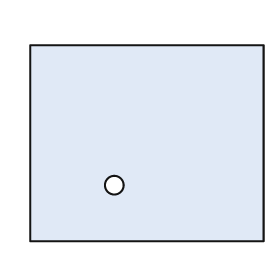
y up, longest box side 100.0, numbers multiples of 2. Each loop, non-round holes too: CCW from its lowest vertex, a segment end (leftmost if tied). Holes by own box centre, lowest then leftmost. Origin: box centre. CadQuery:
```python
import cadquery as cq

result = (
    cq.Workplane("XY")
    .moveTo(-50.0, -42.0)
    .lineTo(50.0, -42.0)
    .lineTo(50.0, 42.0)
    .lineTo(-50.0, 42.0)
    .close()
    .moveTo(-14.0, -18.0)
    .circle(4.0)
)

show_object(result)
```